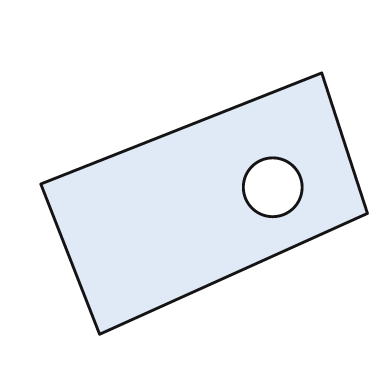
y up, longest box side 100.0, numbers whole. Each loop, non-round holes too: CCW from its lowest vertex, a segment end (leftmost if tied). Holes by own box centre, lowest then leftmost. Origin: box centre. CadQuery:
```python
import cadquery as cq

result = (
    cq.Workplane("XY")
    .moveTo(-32.0, -40.0)
    .lineTo(50.0, -3.0)
    .lineTo(36.0, 40.0)
    .lineTo(-50.0, 6.0)
    .close()
    .moveTo(21.0, 5.0)
    .circle(9.0)
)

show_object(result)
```